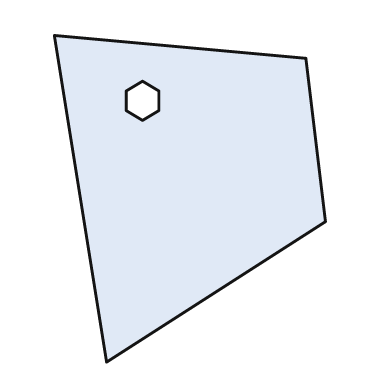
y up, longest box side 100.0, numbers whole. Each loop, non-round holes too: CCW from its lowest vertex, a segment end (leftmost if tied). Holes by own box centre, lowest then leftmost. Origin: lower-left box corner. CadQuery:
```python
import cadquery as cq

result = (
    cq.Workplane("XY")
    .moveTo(16.0, 0.0)
    .lineTo(83.0, 43.0)
    .lineTo(77.0, 93.0)
    .lineTo(0.0, 100.0)
    .close()
    .moveTo(27.0, 74.0)
    .lineTo(32.0, 77.0)
    .lineTo(32.0, 83.0)
    .lineTo(27.0, 86.0)
    .lineTo(22.0, 83.0)
    .lineTo(22.0, 77.0)
    .close()
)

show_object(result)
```